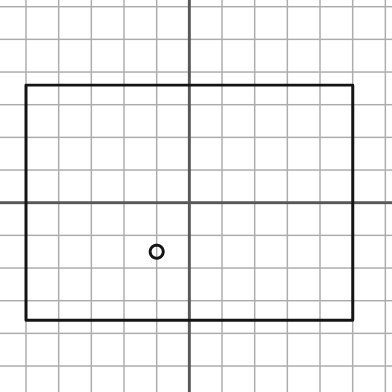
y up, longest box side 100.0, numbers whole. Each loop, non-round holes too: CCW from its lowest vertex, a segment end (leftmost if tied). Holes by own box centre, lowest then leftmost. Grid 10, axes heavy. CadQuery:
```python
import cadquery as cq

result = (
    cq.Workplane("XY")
    .moveTo(-50.0, -36.0)
    .lineTo(50.0, -36.0)
    .lineTo(50.0, 36.0)
    .lineTo(-50.0, 36.0)
    .close()
    .moveTo(-10.0, -15.0)
    .circle(2.0)
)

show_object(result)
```